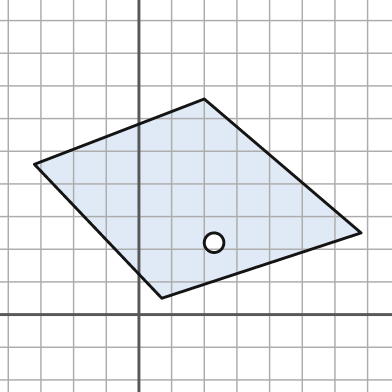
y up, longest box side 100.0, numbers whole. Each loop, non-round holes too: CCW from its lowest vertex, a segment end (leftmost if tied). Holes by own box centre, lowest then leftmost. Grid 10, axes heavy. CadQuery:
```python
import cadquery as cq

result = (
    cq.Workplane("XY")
    .moveTo(7.0, 5.0)
    .lineTo(68.0, 25.0)
    .lineTo(20.0, 66.0)
    .lineTo(-32.0, 46.0)
    .close()
    .moveTo(23.0, 22.0)
    .circle(3.0)
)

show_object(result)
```